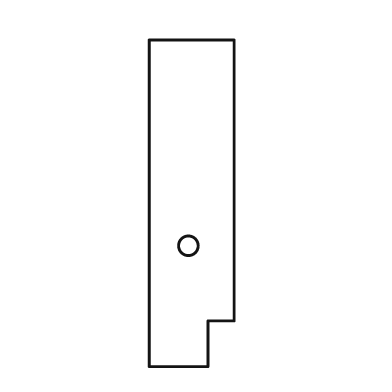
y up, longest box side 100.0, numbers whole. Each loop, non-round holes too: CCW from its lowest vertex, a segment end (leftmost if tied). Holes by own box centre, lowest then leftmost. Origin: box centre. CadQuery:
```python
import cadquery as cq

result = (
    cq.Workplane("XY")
    .moveTo(-13.0, -50.0)
    .lineTo(5.0, -50.0)
    .lineTo(5.0, -36.0)
    .lineTo(13.0, -36.0)
    .lineTo(13.0, 50.0)
    .lineTo(-13.0, 50.0)
    .close()
    .moveTo(-1.0, -13.0)
    .circle(3.0)
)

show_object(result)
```